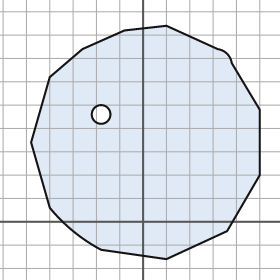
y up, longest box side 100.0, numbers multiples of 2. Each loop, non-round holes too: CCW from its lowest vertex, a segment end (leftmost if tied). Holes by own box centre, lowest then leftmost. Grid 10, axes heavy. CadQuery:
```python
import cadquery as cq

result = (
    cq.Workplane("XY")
    .moveTo(10.0, -16.0)
    .lineTo(36.0, -4.0)
    .lineTo(50.0, 20.0)
    .lineTo(50.0, 48.0)
    .lineTo(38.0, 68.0)
    .threePointArc((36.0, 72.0), (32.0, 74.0))
    .lineTo(10.0, 84.0)
    .lineTo(-8.0, 82.0)
    .lineTo(-26.0, 74.0)
    .lineTo(-40.0, 62.0)
    .lineTo(-48.0, 34.0)
    .lineTo(-40.0, 6.0)
    .threePointArc((-30.0, -4.0), (-18.0, -12.0))
    .close()
    .moveTo(-18.0, 46.0)
    .circle(4.0)
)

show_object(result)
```